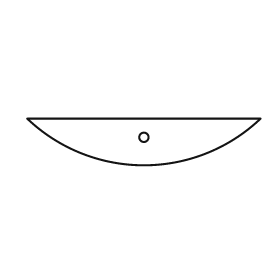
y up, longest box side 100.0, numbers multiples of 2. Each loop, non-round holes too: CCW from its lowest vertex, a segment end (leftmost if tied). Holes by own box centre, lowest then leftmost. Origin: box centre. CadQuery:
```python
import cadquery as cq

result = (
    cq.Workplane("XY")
    .moveTo(-50.0, 10.0)
    .threePointArc((0.0, -10.0), (50.0, 10.0))
    .close()
    .moveTo(0.0, 2.0)
    .circle(2.0)
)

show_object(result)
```